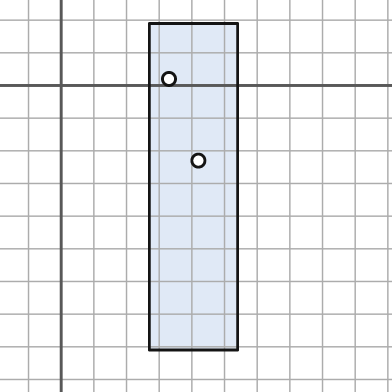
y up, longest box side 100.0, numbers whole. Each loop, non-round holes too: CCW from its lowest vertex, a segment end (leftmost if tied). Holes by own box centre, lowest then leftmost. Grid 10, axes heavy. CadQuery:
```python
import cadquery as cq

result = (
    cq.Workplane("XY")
    .moveTo(27.0, -81.0)
    .lineTo(54.0, -81.0)
    .lineTo(54.0, 19.0)
    .lineTo(27.0, 19.0)
    .close()
    .moveTo(42.0, -23.0)
    .circle(2.0)
    .moveTo(33.0, 2.0)
    .circle(2.0)
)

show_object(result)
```